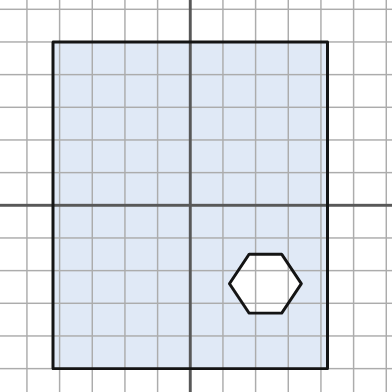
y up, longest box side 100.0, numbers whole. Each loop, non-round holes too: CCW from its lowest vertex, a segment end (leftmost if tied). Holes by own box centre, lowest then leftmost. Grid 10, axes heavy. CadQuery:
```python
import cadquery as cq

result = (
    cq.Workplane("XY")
    .moveTo(-42.0, -50.0)
    .lineTo(42.0, -50.0)
    .lineTo(42.0, 50.0)
    .lineTo(-42.0, 50.0)
    .close()
    .moveTo(18.0, -33.0)
    .lineTo(28.0, -33.0)
    .lineTo(34.0, -24.0)
    .lineTo(28.0, -15.0)
    .lineTo(18.0, -15.0)
    .lineTo(12.0, -24.0)
    .close()
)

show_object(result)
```